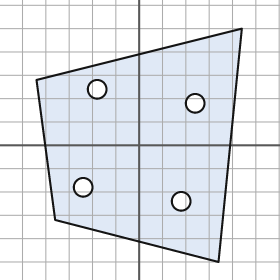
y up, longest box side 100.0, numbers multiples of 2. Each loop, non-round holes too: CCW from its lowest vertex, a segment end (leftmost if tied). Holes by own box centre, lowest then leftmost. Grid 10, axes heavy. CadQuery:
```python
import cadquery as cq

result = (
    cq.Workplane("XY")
    .moveTo(34.0, -50.0)
    .lineTo(44.0, 50.0)
    .lineTo(-44.0, 28.0)
    .lineTo(-36.0, -32.0)
    .close()
    .moveTo(18.0, -24.0)
    .circle(4.0)
    .moveTo(-24.0, -18.0)
    .circle(4.0)
    .moveTo(24.0, 18.0)
    .circle(4.0)
    .moveTo(-18.0, 24.0)
    .circle(4.0)
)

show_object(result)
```